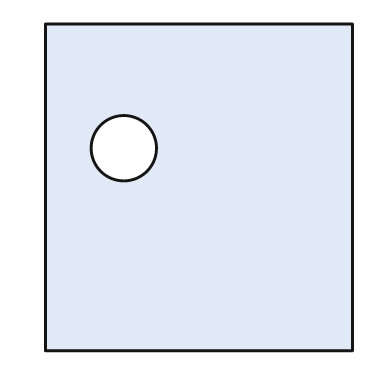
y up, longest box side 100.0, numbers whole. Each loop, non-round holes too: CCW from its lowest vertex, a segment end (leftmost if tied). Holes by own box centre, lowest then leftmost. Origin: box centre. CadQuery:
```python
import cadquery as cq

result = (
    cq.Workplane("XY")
    .moveTo(-47.0, -50.0)
    .lineTo(47.0, -50.0)
    .lineTo(47.0, 50.0)
    .lineTo(-47.0, 50.0)
    .close()
    .moveTo(-23.0, 12.0)
    .circle(10.0)
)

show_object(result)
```